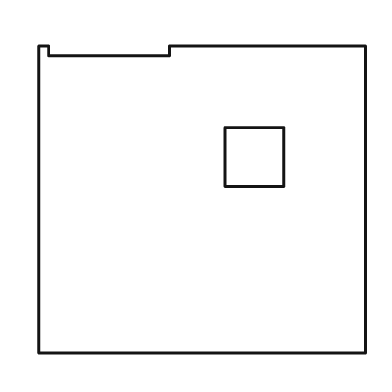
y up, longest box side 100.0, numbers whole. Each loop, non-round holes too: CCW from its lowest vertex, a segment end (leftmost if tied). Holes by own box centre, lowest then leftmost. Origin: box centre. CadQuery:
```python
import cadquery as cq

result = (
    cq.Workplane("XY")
    .moveTo(-50.0, -47.0)
    .lineTo(50.0, -47.0)
    .lineTo(50.0, 47.0)
    .lineTo(-10.0, 47.0)
    .lineTo(-10.0, 44.0)
    .lineTo(-47.0, 44.0)
    .lineTo(-47.0, 47.0)
    .lineTo(-50.0, 47.0)
    .close()
    .moveTo(7.0, 4.0)
    .lineTo(25.0, 4.0)
    .lineTo(25.0, 22.0)
    .lineTo(7.0, 22.0)
    .close()
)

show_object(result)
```